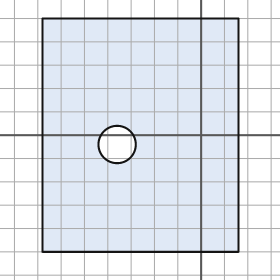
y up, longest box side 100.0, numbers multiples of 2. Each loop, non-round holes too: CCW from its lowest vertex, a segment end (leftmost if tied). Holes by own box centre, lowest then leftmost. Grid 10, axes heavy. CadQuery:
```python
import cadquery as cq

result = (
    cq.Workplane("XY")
    .moveTo(-68.0, -50.0)
    .lineTo(16.0, -50.0)
    .lineTo(16.0, 50.0)
    .lineTo(-68.0, 50.0)
    .close()
    .moveTo(-36.0, -4.0)
    .circle(8.0)
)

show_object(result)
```